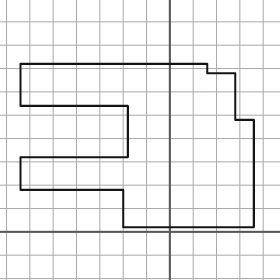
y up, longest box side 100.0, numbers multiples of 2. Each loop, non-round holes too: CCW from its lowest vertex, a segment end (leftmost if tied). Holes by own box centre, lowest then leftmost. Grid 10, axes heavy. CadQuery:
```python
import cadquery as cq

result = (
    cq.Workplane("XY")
    .moveTo(-20.0, 2.0)
    .lineTo(36.0, 2.0)
    .lineTo(36.0, 48.0)
    .lineTo(28.0, 48.0)
    .lineTo(28.0, 68.0)
    .lineTo(16.0, 68.0)
    .lineTo(16.0, 72.0)
    .lineTo(-64.0, 72.0)
    .lineTo(-64.0, 54.0)
    .lineTo(-18.0, 54.0)
    .lineTo(-18.0, 32.0)
    .lineTo(-64.0, 32.0)
    .lineTo(-64.0, 18.0)
    .lineTo(-20.0, 18.0)
    .close()
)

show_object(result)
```